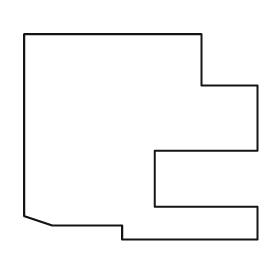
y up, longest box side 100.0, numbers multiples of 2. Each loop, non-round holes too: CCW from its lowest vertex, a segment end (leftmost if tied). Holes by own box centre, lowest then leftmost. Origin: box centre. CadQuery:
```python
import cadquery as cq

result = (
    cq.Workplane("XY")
    .moveTo(-8.0, -44.0)
    .lineTo(50.0, -44.0)
    .lineTo(50.0, -30.0)
    .lineTo(6.0, -30.0)
    .lineTo(6.0, -6.0)
    .lineTo(50.0, -6.0)
    .lineTo(50.0, 22.0)
    .lineTo(26.0, 22.0)
    .lineTo(26.0, 44.0)
    .lineTo(-50.0, 44.0)
    .lineTo(-50.0, -34.0)
    .lineTo(-38.0, -38.0)
    .lineTo(-8.0, -38.0)
    .close()
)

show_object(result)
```